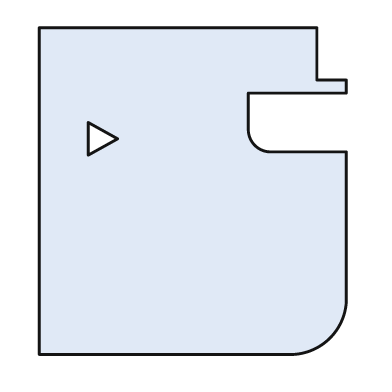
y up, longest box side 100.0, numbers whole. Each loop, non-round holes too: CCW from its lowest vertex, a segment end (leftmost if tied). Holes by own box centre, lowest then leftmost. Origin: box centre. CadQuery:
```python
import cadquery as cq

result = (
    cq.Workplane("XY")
    .moveTo(-47.0, -50.0)
    .lineTo(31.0, -50.0)
    .threePointArc((42.0, -45.0), (47.0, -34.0))
    .lineTo(47.0, 12.0)
    .lineTo(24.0, 12.0)
    .threePointArc((19.0, 14.0), (17.0, 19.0))
    .lineTo(17.0, 30.0)
    .lineTo(47.0, 30.0)
    .lineTo(47.0, 34.0)
    .lineTo(38.0, 34.0)
    .lineTo(38.0, 50.0)
    .lineTo(-47.0, 50.0)
    .close()
    .moveTo(-32.0, 11.0)
    .lineTo(-23.0, 16.0)
    .lineTo(-32.0, 21.0)
    .close()
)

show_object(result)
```